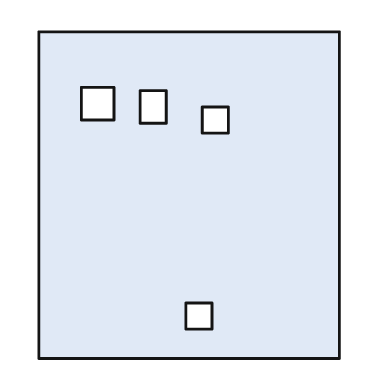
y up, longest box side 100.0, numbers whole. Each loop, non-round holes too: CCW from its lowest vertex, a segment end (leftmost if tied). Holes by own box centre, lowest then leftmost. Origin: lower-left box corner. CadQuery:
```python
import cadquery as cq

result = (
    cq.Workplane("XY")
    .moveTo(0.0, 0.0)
    .lineTo(92.0, 0.0)
    .lineTo(92.0, 100.0)
    .lineTo(0.0, 100.0)
    .close()
    .moveTo(45.0, 9.0)
    .lineTo(53.0, 9.0)
    .lineTo(53.0, 17.0)
    .lineTo(45.0, 17.0)
    .close()
    .moveTo(50.0, 69.0)
    .lineTo(58.0, 69.0)
    .lineTo(58.0, 77.0)
    .lineTo(50.0, 77.0)
    .close()
    .moveTo(31.0, 72.0)
    .lineTo(39.0, 72.0)
    .lineTo(39.0, 82.0)
    .lineTo(31.0, 82.0)
    .close()
    .moveTo(13.0, 73.0)
    .lineTo(23.0, 73.0)
    .lineTo(23.0, 83.0)
    .lineTo(13.0, 83.0)
    .close()
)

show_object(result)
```